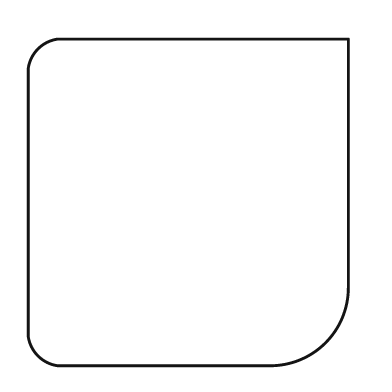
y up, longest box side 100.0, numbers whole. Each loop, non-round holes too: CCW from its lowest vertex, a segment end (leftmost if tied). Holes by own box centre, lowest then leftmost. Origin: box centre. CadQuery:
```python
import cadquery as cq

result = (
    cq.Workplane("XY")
    .moveTo(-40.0, -50.0)
    .lineTo(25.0, -50.0)
    .threePointArc((42.0, -43.0), (49.0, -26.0))
    .lineTo(49.0, 50.0)
    .lineTo(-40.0, 50.0)
    .threePointArc((-46.0, 47.0), (-49.0, 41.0))
    .lineTo(-49.0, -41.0)
    .threePointArc((-46.0, -47.0), (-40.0, -50.0))
    .close()
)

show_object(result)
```